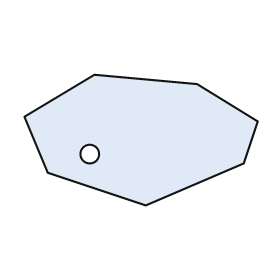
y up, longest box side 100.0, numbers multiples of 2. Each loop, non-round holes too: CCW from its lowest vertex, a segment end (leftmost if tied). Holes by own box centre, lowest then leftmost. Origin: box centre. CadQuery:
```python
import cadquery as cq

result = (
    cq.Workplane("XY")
    .moveTo(2.0, -28.0)
    .lineTo(44.0, -10.0)
    .lineTo(50.0, 8.0)
    .lineTo(24.0, 24.0)
    .lineTo(-20.0, 28.0)
    .lineTo(-50.0, 10.0)
    .lineTo(-40.0, -14.0)
    .close()
    .moveTo(-22.0, -6.0)
    .circle(4.0)
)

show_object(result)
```